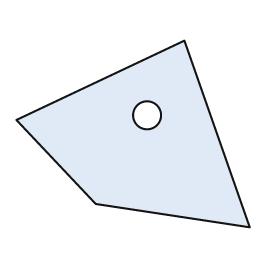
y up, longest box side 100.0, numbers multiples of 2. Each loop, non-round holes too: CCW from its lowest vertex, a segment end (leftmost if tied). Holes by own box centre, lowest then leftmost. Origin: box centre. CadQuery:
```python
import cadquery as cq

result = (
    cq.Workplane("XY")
    .moveTo(50.0, -40.0)
    .lineTo(22.0, 40.0)
    .lineTo(-50.0, 6.0)
    .lineTo(-16.0, -30.0)
    .close()
    .moveTo(6.0, 8.0)
    .circle(6.0)
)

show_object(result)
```